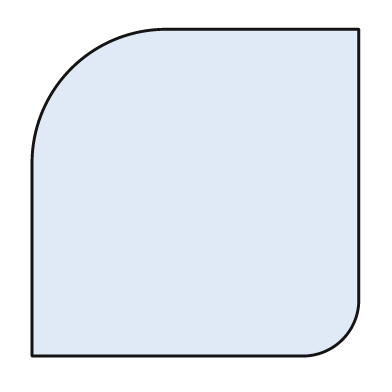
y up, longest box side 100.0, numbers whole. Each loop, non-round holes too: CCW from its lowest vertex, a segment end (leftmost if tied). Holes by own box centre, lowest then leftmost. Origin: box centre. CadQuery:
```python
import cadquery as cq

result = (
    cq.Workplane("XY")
    .moveTo(-50.0, -50.0)
    .lineTo(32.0, -50.0)
    .threePointArc((45.0, -45.0), (50.0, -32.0))
    .lineTo(50.0, 50.0)
    .lineTo(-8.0, 50.0)
    .threePointArc((-38.0, 38.0), (-50.0, 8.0))
    .close()
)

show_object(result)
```